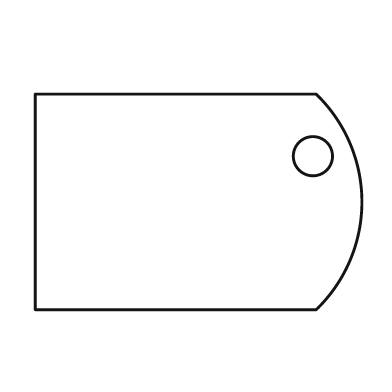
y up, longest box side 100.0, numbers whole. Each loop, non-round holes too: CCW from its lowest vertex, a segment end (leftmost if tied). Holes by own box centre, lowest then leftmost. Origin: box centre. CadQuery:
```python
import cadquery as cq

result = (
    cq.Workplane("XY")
    .moveTo(-50.0, -33.0)
    .lineTo(36.0, -33.0)
    .threePointArc((50.0, 0.0), (36.0, 33.0))
    .lineTo(-50.0, 33.0)
    .close()
    .moveTo(35.0, 14.0)
    .circle(6.0)
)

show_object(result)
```